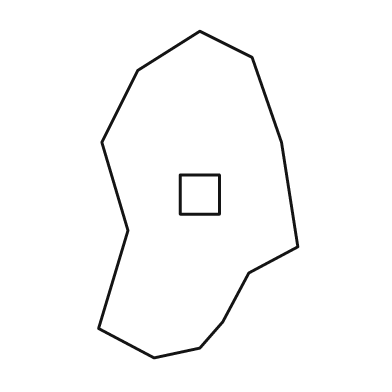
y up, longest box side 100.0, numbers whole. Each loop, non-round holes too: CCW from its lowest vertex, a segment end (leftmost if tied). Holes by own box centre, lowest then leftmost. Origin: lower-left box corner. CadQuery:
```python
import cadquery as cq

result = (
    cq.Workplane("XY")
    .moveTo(17.0, 0.0)
    .lineTo(31.0, 3.0)
    .lineTo(38.0, 11.0)
    .lineTo(46.0, 26.0)
    .lineTo(61.0, 34.0)
    .lineTo(56.0, 66.0)
    .lineTo(47.0, 92.0)
    .lineTo(31.0, 100.0)
    .lineTo(12.0, 88.0)
    .lineTo(1.0, 66.0)
    .lineTo(9.0, 39.0)
    .lineTo(0.0, 9.0)
    .close()
    .moveTo(25.0, 44.0)
    .lineTo(37.0, 44.0)
    .lineTo(37.0, 56.0)
    .lineTo(25.0, 56.0)
    .close()
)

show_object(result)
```